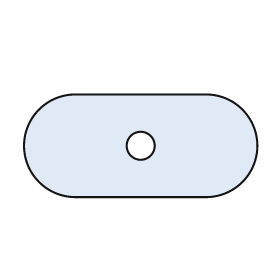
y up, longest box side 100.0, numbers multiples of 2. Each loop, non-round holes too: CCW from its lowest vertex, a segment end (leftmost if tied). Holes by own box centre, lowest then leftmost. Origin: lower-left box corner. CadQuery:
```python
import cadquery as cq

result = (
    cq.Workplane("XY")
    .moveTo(22.0, 0.0)
    .lineTo(78.0, 0.0)
    .threePointArc((100.0, 22.0), (78.0, 44.0))
    .lineTo(22.0, 44.0)
    .threePointArc((0.0, 22.0), (22.0, 0.0))
    .close()
    .moveTo(50.0, 22.0)
    .circle(6.0)
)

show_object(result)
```